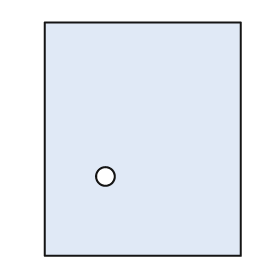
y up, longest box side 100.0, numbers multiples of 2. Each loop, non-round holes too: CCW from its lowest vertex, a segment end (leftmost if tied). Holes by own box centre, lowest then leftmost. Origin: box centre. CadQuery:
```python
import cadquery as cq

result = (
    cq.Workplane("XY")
    .moveTo(-42.0, -50.0)
    .lineTo(42.0, -50.0)
    .lineTo(42.0, 50.0)
    .lineTo(-42.0, 50.0)
    .close()
    .moveTo(-16.0, -16.0)
    .circle(4.0)
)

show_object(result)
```